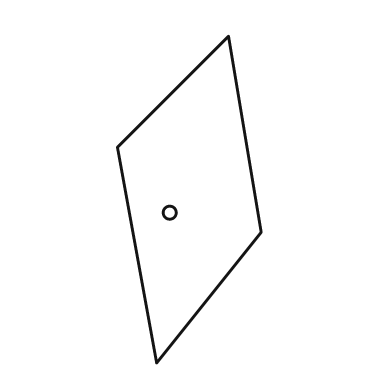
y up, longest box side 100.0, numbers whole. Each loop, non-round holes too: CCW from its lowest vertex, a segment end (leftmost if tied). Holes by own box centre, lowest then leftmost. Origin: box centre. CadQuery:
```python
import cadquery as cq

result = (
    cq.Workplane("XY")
    .moveTo(-10.0, -50.0)
    .lineTo(22.0, -10.0)
    .lineTo(12.0, 50.0)
    .lineTo(-22.0, 16.0)
    .close()
    .moveTo(-6.0, -4.0)
    .circle(2.0)
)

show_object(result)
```